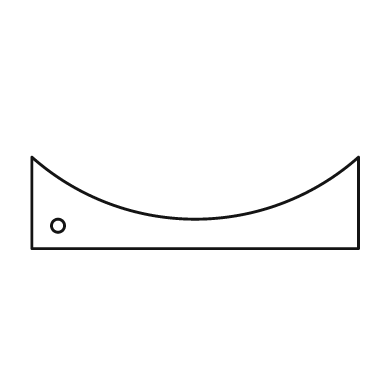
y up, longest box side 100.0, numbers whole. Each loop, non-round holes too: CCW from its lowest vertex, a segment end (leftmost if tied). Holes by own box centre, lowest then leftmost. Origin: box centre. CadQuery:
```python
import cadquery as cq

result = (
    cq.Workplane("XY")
    .moveTo(-50.0, -14.0)
    .lineTo(50.0, -14.0)
    .lineTo(50.0, 14.0)
    .threePointArc((0.0, -5.0), (-50.0, 14.0))
    .close()
    .moveTo(-42.0, -7.0)
    .circle(2.0)
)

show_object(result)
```